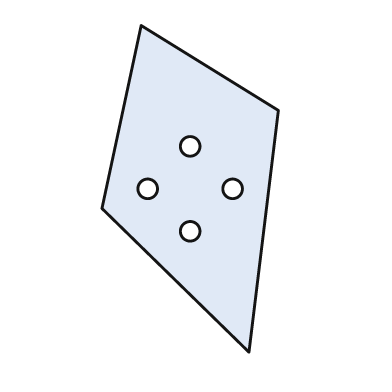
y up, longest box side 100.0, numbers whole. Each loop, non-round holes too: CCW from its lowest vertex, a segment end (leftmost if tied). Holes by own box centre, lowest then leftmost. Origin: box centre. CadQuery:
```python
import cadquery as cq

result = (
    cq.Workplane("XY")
    .moveTo(18.0, -50.0)
    .lineTo(27.0, 24.0)
    .lineTo(-15.0, 50.0)
    .lineTo(-27.0, -6.0)
    .close()
    .moveTo(0.0, -13.0)
    .circle(3.0)
    .moveTo(-13.0, 0.0)
    .circle(3.0)
    .moveTo(13.0, 0.0)
    .circle(3.0)
    .moveTo(0.0, 13.0)
    .circle(3.0)
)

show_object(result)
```